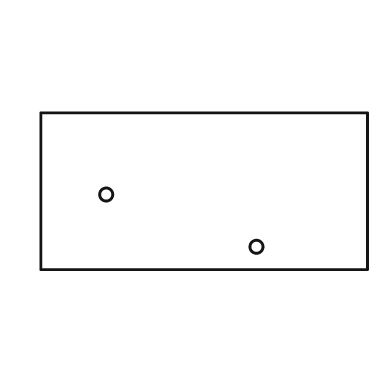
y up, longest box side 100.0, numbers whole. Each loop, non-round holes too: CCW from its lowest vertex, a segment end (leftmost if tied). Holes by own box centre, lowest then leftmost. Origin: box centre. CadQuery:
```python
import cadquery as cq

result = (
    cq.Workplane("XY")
    .moveTo(-50.0, -24.0)
    .lineTo(50.0, -24.0)
    .lineTo(50.0, 24.0)
    .lineTo(-50.0, 24.0)
    .close()
    .moveTo(16.0, -17.0)
    .circle(2.0)
    .moveTo(-30.0, -1.0)
    .circle(2.0)
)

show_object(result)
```